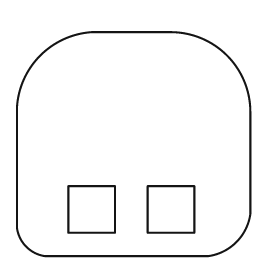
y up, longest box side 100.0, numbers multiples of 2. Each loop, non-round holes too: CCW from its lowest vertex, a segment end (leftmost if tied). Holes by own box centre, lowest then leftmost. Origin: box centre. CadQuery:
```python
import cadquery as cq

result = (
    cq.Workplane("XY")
    .moveTo(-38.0, -48.0)
    .lineTo(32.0, -48.0)
    .threePointArc((44.0, -42.0), (50.0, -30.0))
    .lineTo(50.0, 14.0)
    .threePointArc((40.0, 38.0), (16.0, 48.0))
    .lineTo(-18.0, 48.0)
    .threePointArc((-40.0, 38.0), (-50.0, 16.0))
    .lineTo(-50.0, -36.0)
    .threePointArc((-46.0, -44.0), (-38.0, -48.0))
    .close()
    .moveTo(-28.0, -38.0)
    .lineTo(-8.0, -38.0)
    .lineTo(-8.0, -18.0)
    .lineTo(-28.0, -18.0)
    .close()
    .moveTo(6.0, -38.0)
    .lineTo(26.0, -38.0)
    .lineTo(26.0, -18.0)
    .lineTo(6.0, -18.0)
    .close()
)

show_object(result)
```